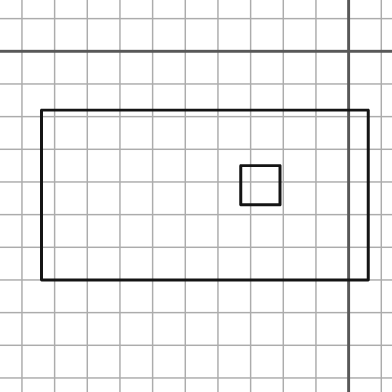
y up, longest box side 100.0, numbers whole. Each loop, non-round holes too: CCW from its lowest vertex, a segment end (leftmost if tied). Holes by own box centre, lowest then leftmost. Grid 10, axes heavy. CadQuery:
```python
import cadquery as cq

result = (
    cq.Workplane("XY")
    .moveTo(-94.0, -70.0)
    .lineTo(6.0, -70.0)
    .lineTo(6.0, -18.0)
    .lineTo(-94.0, -18.0)
    .close()
    .moveTo(-33.0, -47.0)
    .lineTo(-21.0, -47.0)
    .lineTo(-21.0, -35.0)
    .lineTo(-33.0, -35.0)
    .close()
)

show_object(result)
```